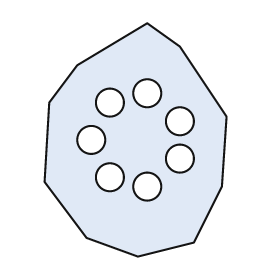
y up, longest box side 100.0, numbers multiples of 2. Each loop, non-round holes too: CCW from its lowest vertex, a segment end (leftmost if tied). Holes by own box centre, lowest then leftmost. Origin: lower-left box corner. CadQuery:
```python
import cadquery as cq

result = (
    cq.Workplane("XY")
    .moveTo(40.0, 0.0)
    .lineTo(64.0, 6.0)
    .lineTo(76.0, 30.0)
    .lineTo(78.0, 60.0)
    .lineTo(58.0, 90.0)
    .lineTo(44.0, 100.0)
    .lineTo(14.0, 82.0)
    .lineTo(2.0, 66.0)
    .lineTo(0.0, 32.0)
    .lineTo(18.0, 8.0)
    .close()
    .moveTo(44.0, 30.0)
    .circle(6.0)
    .moveTo(28.0, 34.0)
    .circle(6.0)
    .moveTo(58.0, 42.0)
    .circle(6.0)
    .moveTo(20.0, 50.0)
    .circle(6.0)
    .moveTo(58.0, 58.0)
    .circle(6.0)
    .moveTo(28.0, 66.0)
    .circle(6.0)
    .moveTo(44.0, 70.0)
    .circle(6.0)
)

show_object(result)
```